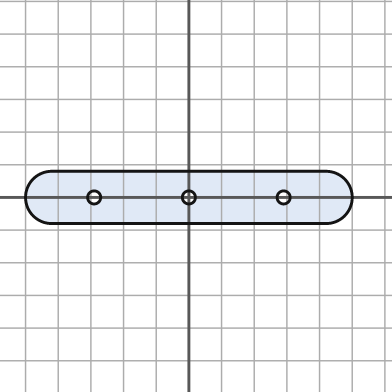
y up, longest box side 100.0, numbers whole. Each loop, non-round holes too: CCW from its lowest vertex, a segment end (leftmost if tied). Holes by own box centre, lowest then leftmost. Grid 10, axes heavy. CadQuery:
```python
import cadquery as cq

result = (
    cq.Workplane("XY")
    .moveTo(-42.0, -8.0)
    .lineTo(42.0, -8.0)
    .threePointArc((50.0, 0.0), (42.0, 8.0))
    .lineTo(-42.0, 8.0)
    .threePointArc((-50.0, 0.0), (-42.0, -8.0))
    .close()
    .moveTo(-29.0, 0.0)
    .circle(2.0)
    .moveTo(0.0, 0.0)
    .circle(2.0)
    .moveTo(29.0, 0.0)
    .circle(2.0)
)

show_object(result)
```